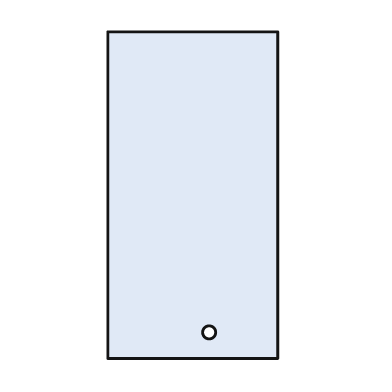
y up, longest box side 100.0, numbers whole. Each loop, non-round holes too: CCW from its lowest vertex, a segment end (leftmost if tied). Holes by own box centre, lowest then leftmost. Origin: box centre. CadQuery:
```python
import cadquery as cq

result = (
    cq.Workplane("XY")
    .moveTo(-26.0, -50.0)
    .lineTo(26.0, -50.0)
    .lineTo(26.0, 50.0)
    .lineTo(-26.0, 50.0)
    .close()
    .moveTo(5.0, -42.0)
    .circle(2.0)
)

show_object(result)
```